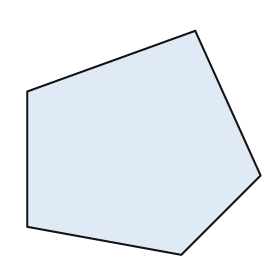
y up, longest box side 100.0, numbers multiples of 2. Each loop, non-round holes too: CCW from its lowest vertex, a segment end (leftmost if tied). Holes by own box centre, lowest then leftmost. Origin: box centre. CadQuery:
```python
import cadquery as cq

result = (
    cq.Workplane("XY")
    .moveTo(16.0, -48.0)
    .lineTo(50.0, -14.0)
    .lineTo(22.0, 48.0)
    .lineTo(-50.0, 22.0)
    .lineTo(-50.0, -36.0)
    .close()
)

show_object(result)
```